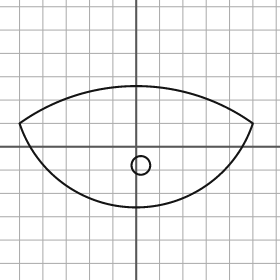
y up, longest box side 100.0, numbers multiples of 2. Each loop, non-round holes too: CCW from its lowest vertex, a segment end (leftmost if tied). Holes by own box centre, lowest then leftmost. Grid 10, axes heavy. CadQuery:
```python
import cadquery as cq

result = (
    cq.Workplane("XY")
    .moveTo(-50.0, 10.0)
    .threePointArc((0.0, -26.0), (50.0, 10.0))
    .threePointArc((0.0, 26.0), (-50.0, 10.0))
    .close()
    .moveTo(2.0, -8.0)
    .circle(4.0)
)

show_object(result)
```